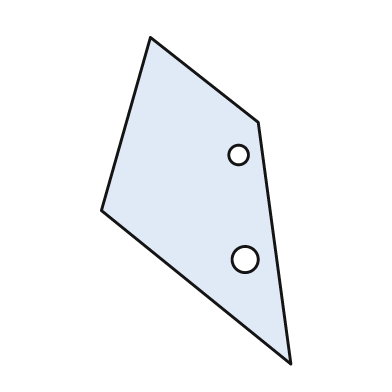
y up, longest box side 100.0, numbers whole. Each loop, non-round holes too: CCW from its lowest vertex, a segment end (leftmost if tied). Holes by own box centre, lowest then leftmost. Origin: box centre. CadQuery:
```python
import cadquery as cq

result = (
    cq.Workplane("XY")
    .moveTo(29.0, -50.0)
    .lineTo(19.0, 24.0)
    .lineTo(-14.0, 50.0)
    .lineTo(-29.0, -3.0)
    .close()
    .moveTo(15.0, -18.0)
    .circle(4.0)
    .moveTo(13.0, 14.0)
    .circle(3.0)
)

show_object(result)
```